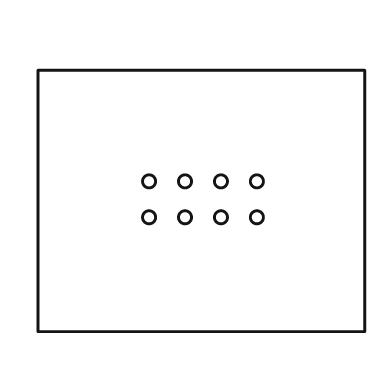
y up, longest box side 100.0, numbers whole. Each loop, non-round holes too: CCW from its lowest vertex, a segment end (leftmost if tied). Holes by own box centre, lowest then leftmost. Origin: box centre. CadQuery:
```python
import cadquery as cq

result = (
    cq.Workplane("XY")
    .moveTo(-50.0, -40.0)
    .lineTo(50.0, -40.0)
    .lineTo(50.0, 40.0)
    .lineTo(-50.0, 40.0)
    .close()
    .moveTo(-16.0, -5.0)
    .circle(2.0)
    .moveTo(-5.0, -5.0)
    .circle(2.0)
    .moveTo(6.0, -5.0)
    .circle(2.0)
    .moveTo(17.0, -5.0)
    .circle(2.0)
    .moveTo(-16.0, 6.0)
    .circle(2.0)
    .moveTo(-5.0, 6.0)
    .circle(2.0)
    .moveTo(6.0, 6.0)
    .circle(2.0)
    .moveTo(17.0, 6.0)
    .circle(2.0)
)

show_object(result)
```